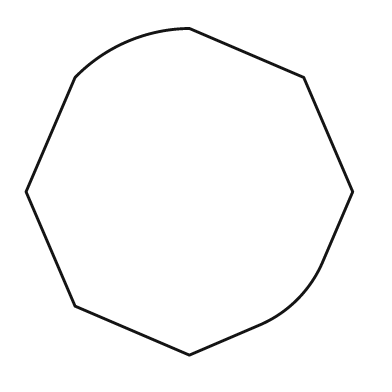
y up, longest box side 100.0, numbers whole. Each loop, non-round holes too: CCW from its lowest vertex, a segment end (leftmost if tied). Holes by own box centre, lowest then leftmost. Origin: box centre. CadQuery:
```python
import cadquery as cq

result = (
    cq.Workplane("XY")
    .moveTo(0.0, -50.0)
    .lineTo(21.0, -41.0)
    .threePointArc((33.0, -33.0), (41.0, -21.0))
    .lineTo(50.0, 0.0)
    .lineTo(35.0, 35.0)
    .lineTo(0.0, 50.0)
    .threePointArc((-19.0, 46.0), (-35.0, 35.0))
    .lineTo(-50.0, 0.0)
    .lineTo(-35.0, -35.0)
    .close()
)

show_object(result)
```